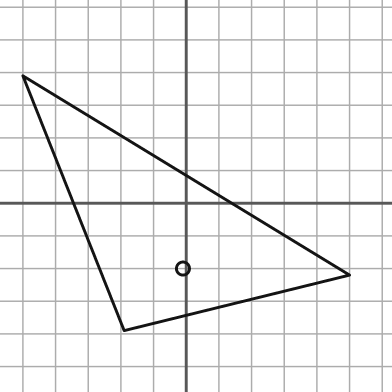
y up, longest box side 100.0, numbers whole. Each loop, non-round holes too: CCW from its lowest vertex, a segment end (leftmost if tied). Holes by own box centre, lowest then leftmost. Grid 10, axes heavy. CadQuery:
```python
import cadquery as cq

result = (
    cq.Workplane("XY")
    .moveTo(-19.0, -39.0)
    .lineTo(50.0, -22.0)
    .lineTo(-50.0, 39.0)
    .close()
    .moveTo(-1.0, -20.0)
    .circle(2.0)
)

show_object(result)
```